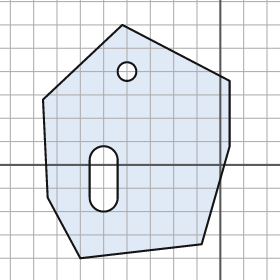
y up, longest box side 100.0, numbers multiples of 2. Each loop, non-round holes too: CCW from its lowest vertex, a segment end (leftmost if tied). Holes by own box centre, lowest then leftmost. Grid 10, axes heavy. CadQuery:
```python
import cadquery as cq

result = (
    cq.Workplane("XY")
    .moveTo(-60.0, -40.0)
    .lineTo(-8.0, -34.0)
    .lineTo(4.0, 8.0)
    .lineTo(4.0, 36.0)
    .lineTo(-42.0, 60.0)
    .lineTo(-76.0, 28.0)
    .lineTo(-74.0, -14.0)
    .close()
    .moveTo(-56.0, -14.0)
    .threePointArc((-50.0, -20.0), (-44.0, -14.0))
    .lineTo(-44.0, 2.0)
    .threePointArc((-50.0, 8.0), (-56.0, 2.0))
    .close()
    .moveTo(-40.0, 40.0)
    .circle(4.0)
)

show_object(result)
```